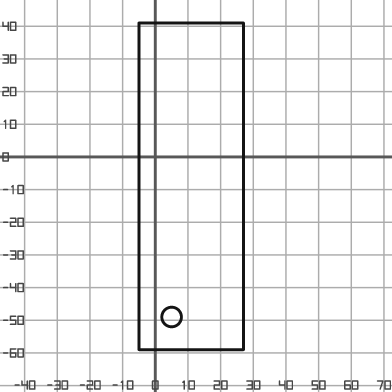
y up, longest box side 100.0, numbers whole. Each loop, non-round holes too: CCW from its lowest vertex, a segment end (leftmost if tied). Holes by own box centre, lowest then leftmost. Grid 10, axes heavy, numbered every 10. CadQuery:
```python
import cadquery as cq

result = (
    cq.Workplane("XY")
    .moveTo(-5.0, -59.0)
    .lineTo(27.0, -59.0)
    .lineTo(27.0, 41.0)
    .lineTo(-5.0, 41.0)
    .close()
    .moveTo(5.0, -49.0)
    .circle(3.0)
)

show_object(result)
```